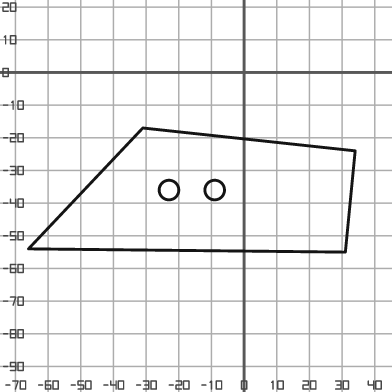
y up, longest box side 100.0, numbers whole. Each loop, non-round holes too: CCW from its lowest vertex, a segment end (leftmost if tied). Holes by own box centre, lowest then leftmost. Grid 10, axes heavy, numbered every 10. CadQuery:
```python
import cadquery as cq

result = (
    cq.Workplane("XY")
    .moveTo(31.0, -55.0)
    .lineTo(34.0, -24.0)
    .lineTo(-31.0, -17.0)
    .lineTo(-66.0, -54.0)
    .close()
    .moveTo(-23.0, -36.0)
    .circle(3.0)
    .moveTo(-9.0, -36.0)
    .circle(3.0)
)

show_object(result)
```